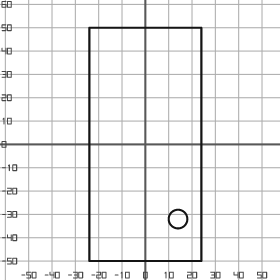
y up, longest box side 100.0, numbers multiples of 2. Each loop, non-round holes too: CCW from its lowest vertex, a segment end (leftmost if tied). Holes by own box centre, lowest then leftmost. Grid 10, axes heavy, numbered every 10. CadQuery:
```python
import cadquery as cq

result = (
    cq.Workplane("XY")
    .moveTo(-24.0, -50.0)
    .lineTo(24.0, -50.0)
    .lineTo(24.0, 50.0)
    .lineTo(-24.0, 50.0)
    .close()
    .moveTo(14.0, -32.0)
    .circle(4.0)
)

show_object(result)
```